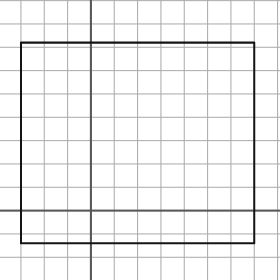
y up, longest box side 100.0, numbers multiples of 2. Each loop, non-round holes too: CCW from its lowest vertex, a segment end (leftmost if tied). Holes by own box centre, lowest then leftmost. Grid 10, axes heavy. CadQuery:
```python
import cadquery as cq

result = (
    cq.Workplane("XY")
    .moveTo(-30.0, -14.0)
    .lineTo(70.0, -14.0)
    .lineTo(70.0, 72.0)
    .lineTo(-30.0, 72.0)
    .close()
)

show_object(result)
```